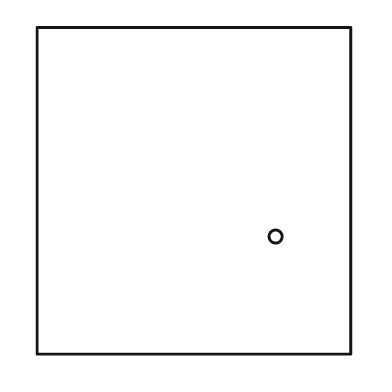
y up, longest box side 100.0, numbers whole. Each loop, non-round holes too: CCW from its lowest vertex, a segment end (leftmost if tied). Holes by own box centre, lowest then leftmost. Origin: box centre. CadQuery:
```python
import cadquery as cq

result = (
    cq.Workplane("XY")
    .moveTo(-48.0, -50.0)
    .lineTo(48.0, -50.0)
    .lineTo(48.0, 50.0)
    .lineTo(-48.0, 50.0)
    .close()
    .moveTo(25.0, -14.0)
    .circle(2.0)
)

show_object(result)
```